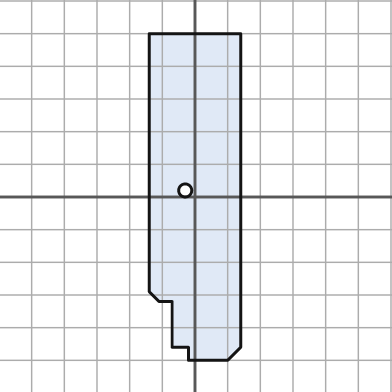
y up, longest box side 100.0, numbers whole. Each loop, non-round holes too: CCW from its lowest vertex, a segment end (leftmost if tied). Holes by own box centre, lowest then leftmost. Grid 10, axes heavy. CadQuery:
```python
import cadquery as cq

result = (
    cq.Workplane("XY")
    .moveTo(-2.0, -50.0)
    .lineTo(10.0, -50.0)
    .lineTo(14.0, -46.0)
    .lineTo(14.0, 50.0)
    .lineTo(-14.0, 50.0)
    .lineTo(-14.0, -29.0)
    .lineTo(-11.0, -32.0)
    .lineTo(-7.0, -32.0)
    .lineTo(-7.0, -46.0)
    .lineTo(-2.0, -46.0)
    .close()
    .moveTo(-3.0, 2.0)
    .circle(2.0)
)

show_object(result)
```